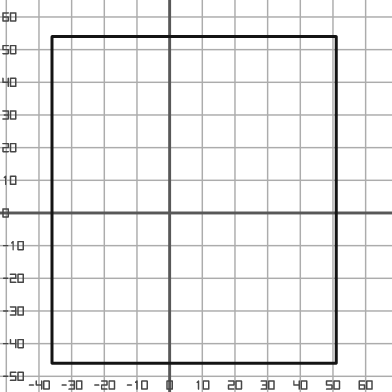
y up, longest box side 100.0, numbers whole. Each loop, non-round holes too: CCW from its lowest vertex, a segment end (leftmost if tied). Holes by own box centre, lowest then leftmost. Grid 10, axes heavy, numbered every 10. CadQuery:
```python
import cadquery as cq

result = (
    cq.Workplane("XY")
    .moveTo(-36.0, -46.0)
    .lineTo(51.0, -46.0)
    .lineTo(51.0, 54.0)
    .lineTo(-36.0, 54.0)
    .close()
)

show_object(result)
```